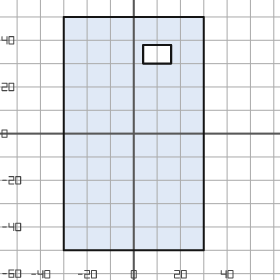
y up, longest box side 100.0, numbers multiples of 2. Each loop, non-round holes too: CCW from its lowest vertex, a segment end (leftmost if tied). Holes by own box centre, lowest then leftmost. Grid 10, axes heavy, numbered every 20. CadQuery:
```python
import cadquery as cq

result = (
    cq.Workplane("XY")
    .moveTo(-30.0, -50.0)
    .lineTo(30.0, -50.0)
    .lineTo(30.0, 50.0)
    .lineTo(-30.0, 50.0)
    .close()
    .moveTo(4.0, 30.0)
    .lineTo(16.0, 30.0)
    .lineTo(16.0, 38.0)
    .lineTo(4.0, 38.0)
    .close()
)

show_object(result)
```